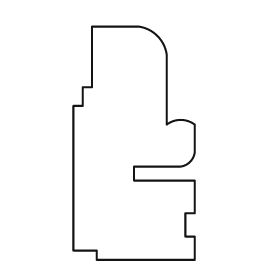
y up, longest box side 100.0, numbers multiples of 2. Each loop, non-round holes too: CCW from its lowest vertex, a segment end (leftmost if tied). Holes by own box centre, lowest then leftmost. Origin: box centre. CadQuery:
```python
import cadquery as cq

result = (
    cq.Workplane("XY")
    .moveTo(-16.0, -50.0)
    .lineTo(26.0, -50.0)
    .lineTo(26.0, -40.0)
    .lineTo(22.0, -40.0)
    .lineTo(22.0, -30.0)
    .lineTo(26.0, -30.0)
    .lineTo(26.0, -16.0)
    .lineTo(0.0, -16.0)
    .lineTo(0.0, -10.0)
    .lineTo(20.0, -10.0)
    .threePointArc((24.0, -8.0), (26.0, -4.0))
    .lineTo(26.0, 8.0)
    .threePointArc((20.0, 10.0), (14.0, 8.0))
    .lineTo(14.0, 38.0)
    .threePointArc((10.0, 46.0), (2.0, 50.0))
    .lineTo(-18.0, 50.0)
    .lineTo(-18.0, 24.0)
    .lineTo(-22.0, 24.0)
    .lineTo(-22.0, 16.0)
    .lineTo(-26.0, 16.0)
    .lineTo(-26.0, -46.0)
    .lineTo(-16.0, -46.0)
    .close()
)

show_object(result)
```